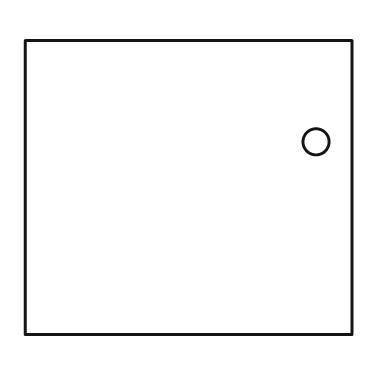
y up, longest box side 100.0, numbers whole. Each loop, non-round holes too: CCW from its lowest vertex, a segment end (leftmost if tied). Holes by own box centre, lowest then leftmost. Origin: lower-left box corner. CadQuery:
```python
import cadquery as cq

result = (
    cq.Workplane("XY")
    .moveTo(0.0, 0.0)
    .lineTo(100.0, 0.0)
    .lineTo(100.0, 90.0)
    .lineTo(0.0, 90.0)
    .close()
    .moveTo(89.0, 59.0)
    .circle(4.0)
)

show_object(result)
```